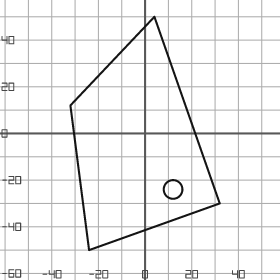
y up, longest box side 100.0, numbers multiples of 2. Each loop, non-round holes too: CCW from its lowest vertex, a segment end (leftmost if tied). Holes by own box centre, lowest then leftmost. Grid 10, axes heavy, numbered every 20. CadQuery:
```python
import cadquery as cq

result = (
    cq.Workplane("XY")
    .moveTo(-24.0, -50.0)
    .lineTo(32.0, -30.0)
    .lineTo(4.0, 50.0)
    .lineTo(-32.0, 12.0)
    .close()
    .moveTo(12.0, -24.0)
    .circle(4.0)
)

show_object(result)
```